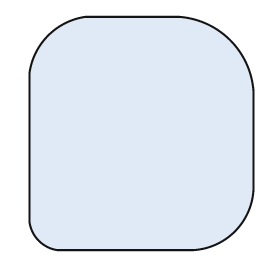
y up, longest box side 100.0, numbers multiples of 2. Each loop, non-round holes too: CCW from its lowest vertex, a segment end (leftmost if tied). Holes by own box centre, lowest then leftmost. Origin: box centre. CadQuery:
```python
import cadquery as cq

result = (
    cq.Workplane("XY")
    .moveTo(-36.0, -50.0)
    .lineTo(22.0, -50.0)
    .threePointArc((40.0, -42.0), (48.0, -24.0))
    .lineTo(48.0, 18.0)
    .threePointArc((38.0, 40.0), (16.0, 50.0))
    .lineTo(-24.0, 50.0)
    .threePointArc((-40.0, 42.0), (-48.0, 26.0))
    .lineTo(-48.0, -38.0)
    .threePointArc((-44.0, -46.0), (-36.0, -50.0))
    .close()
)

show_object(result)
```